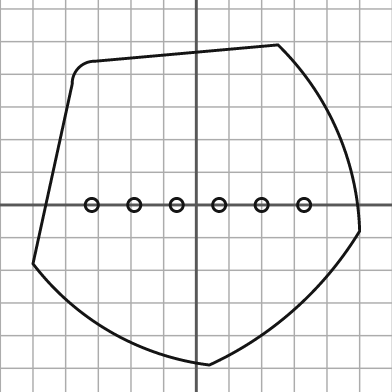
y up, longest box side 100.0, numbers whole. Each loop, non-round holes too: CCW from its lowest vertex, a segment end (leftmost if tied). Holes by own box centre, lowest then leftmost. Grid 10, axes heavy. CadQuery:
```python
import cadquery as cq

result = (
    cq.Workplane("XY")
    .moveTo(4.0, -49.0)
    .threePointArc((30.0, -32.0), (50.0, -8.0))
    .threePointArc((43.0, 23.0), (25.0, 49.0))
    .lineTo(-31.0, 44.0)
    .threePointArc((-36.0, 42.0), (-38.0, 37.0))
    .lineTo(-50.0, -18.0)
    .threePointArc((-26.0, -39.0), (4.0, -49.0))
    .close()
    .moveTo(-32.0, 0.0)
    .circle(2.0)
    .moveTo(-19.0, 0.0)
    .circle(2.0)
    .moveTo(-6.0, 0.0)
    .circle(2.0)
    .moveTo(7.0, 0.0)
    .circle(2.0)
    .moveTo(20.0, 0.0)
    .circle(2.0)
    .moveTo(33.0, 0.0)
    .circle(2.0)
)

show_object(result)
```